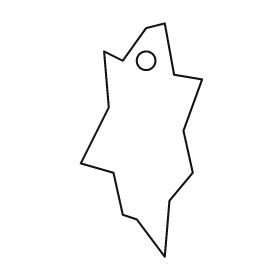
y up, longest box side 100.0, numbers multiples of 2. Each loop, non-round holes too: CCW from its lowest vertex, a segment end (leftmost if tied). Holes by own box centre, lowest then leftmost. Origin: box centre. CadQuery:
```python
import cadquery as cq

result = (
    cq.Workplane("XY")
    .moveTo(10.0, -50.0)
    .lineTo(12.0, -26.0)
    .lineTo(22.0, -14.0)
    .lineTo(18.0, 4.0)
    .lineTo(26.0, 26.0)
    .lineTo(14.0, 28.0)
    .lineTo(10.0, 50.0)
    .lineTo(2.0, 48.0)
    .lineTo(-8.0, 34.0)
    .lineTo(-16.0, 38.0)
    .lineTo(-14.0, 14.0)
    .lineTo(-26.0, -10.0)
    .lineTo(-12.0, -14.0)
    .lineTo(-8.0, -32.0)
    .lineTo(-2.0, -34.0)
    .close()
    .moveTo(2.0, 34.0)
    .circle(4.0)
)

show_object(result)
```